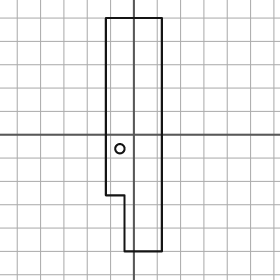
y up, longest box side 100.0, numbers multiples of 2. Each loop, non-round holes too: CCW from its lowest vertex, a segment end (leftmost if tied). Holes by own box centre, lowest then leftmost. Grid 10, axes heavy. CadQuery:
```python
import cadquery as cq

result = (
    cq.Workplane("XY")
    .moveTo(-4.0, -50.0)
    .lineTo(12.0, -50.0)
    .lineTo(12.0, 50.0)
    .lineTo(-12.0, 50.0)
    .lineTo(-12.0, -26.0)
    .lineTo(-4.0, -26.0)
    .close()
    .moveTo(-6.0, -6.0)
    .circle(2.0)
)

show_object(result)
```